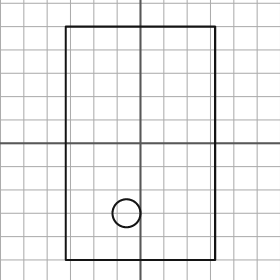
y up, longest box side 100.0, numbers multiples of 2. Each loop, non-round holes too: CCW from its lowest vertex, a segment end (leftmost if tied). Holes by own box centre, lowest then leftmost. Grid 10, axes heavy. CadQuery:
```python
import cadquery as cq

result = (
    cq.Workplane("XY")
    .moveTo(-32.0, -50.0)
    .lineTo(32.0, -50.0)
    .lineTo(32.0, 50.0)
    .lineTo(-32.0, 50.0)
    .close()
    .moveTo(-6.0, -30.0)
    .circle(6.0)
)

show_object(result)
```